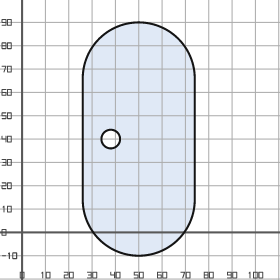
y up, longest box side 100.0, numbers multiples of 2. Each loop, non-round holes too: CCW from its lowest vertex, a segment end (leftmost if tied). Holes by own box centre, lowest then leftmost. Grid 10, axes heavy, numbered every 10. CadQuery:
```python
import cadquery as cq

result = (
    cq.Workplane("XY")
    .moveTo(26.0, 14.0)
    .threePointArc((50.0, -10.0), (74.0, 14.0))
    .lineTo(74.0, 66.0)
    .threePointArc((50.0, 90.0), (26.0, 66.0))
    .close()
    .moveTo(38.0, 40.0)
    .circle(4.0)
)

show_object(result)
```